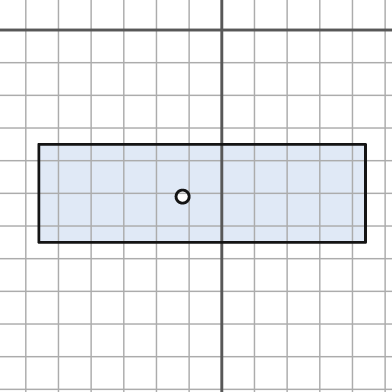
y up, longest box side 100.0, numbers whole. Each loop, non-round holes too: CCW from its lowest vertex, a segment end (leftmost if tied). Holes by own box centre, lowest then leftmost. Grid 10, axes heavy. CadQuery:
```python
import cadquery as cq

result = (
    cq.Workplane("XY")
    .moveTo(-56.0, -65.0)
    .lineTo(44.0, -65.0)
    .lineTo(44.0, -35.0)
    .lineTo(-56.0, -35.0)
    .close()
    .moveTo(-12.0, -51.0)
    .circle(2.0)
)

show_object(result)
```